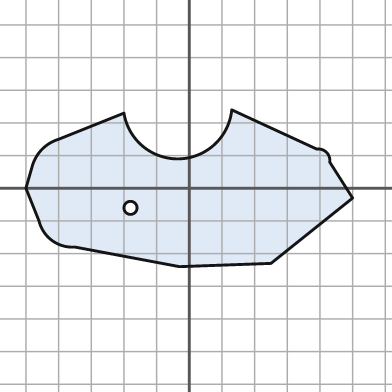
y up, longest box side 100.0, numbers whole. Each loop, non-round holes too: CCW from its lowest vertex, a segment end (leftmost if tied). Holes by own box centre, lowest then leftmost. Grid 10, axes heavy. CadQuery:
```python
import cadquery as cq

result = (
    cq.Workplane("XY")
    .moveTo(-3.0, -24.0)
    .lineTo(25.0, -23.0)
    .lineTo(50.0, -3.0)
    .lineTo(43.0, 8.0)
    .threePointArc((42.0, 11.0), (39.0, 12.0))
    .lineTo(13.0, 24.0)
    .threePointArc((-3.0, 9.0), (-20.0, 23.0))
    .lineTo(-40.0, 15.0)
    .threePointArc((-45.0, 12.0), (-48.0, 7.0))
    .lineTo(-50.0, 0.0)
    .lineTo(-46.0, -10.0)
    .threePointArc((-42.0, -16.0), (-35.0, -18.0))
    .close()
    .moveTo(-18.0, -6.0)
    .circle(2.0)
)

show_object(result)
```